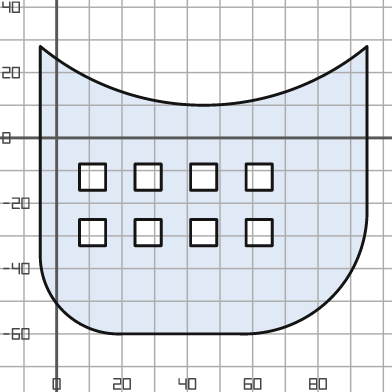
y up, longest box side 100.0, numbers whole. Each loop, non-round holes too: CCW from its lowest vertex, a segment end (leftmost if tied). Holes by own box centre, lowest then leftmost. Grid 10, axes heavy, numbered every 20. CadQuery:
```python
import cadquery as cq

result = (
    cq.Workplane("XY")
    .moveTo(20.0, -60.0)
    .lineTo(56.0, -60.0)
    .threePointArc((84.0, -49.0), (95.0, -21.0))
    .lineTo(95.0, 28.0)
    .threePointArc((45.0, 10.0), (-5.0, 28.0))
    .lineTo(-5.0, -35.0)
    .threePointArc((2.0, -53.0), (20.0, -60.0))
    .close()
    .moveTo(7.0, -33.0)
    .lineTo(15.0, -33.0)
    .lineTo(15.0, -25.0)
    .lineTo(7.0, -25.0)
    .close()
    .moveTo(24.0, -33.0)
    .lineTo(32.0, -33.0)
    .lineTo(32.0, -25.0)
    .lineTo(24.0, -25.0)
    .close()
    .moveTo(41.0, -33.0)
    .lineTo(49.0, -33.0)
    .lineTo(49.0, -25.0)
    .lineTo(41.0, -25.0)
    .close()
    .moveTo(58.0, -33.0)
    .lineTo(66.0, -33.0)
    .lineTo(66.0, -25.0)
    .lineTo(58.0, -25.0)
    .close()
    .moveTo(7.0, -16.0)
    .lineTo(15.0, -16.0)
    .lineTo(15.0, -8.0)
    .lineTo(7.0, -8.0)
    .close()
    .moveTo(24.0, -16.0)
    .lineTo(32.0, -16.0)
    .lineTo(32.0, -8.0)
    .lineTo(24.0, -8.0)
    .close()
    .moveTo(41.0, -16.0)
    .lineTo(49.0, -16.0)
    .lineTo(49.0, -8.0)
    .lineTo(41.0, -8.0)
    .close()
    .moveTo(58.0, -16.0)
    .lineTo(66.0, -16.0)
    .lineTo(66.0, -8.0)
    .lineTo(58.0, -8.0)
    .close()
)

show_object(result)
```